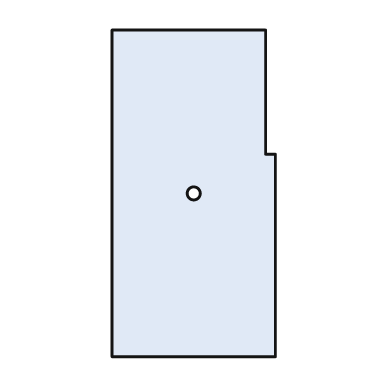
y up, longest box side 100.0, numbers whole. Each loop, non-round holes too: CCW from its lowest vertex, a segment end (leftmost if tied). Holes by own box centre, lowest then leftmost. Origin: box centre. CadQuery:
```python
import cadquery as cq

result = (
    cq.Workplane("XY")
    .moveTo(-25.0, -50.0)
    .lineTo(25.0, -50.0)
    .lineTo(25.0, 12.0)
    .lineTo(22.0, 12.0)
    .lineTo(22.0, 50.0)
    .lineTo(-25.0, 50.0)
    .close()
    .moveTo(0.0, 0.0)
    .circle(2.0)
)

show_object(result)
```